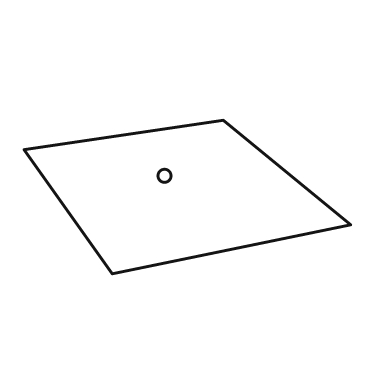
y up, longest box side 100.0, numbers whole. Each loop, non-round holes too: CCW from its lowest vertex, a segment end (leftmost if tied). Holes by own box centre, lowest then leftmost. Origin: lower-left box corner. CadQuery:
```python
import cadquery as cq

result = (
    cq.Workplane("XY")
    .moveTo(27.0, 0.0)
    .lineTo(100.0, 15.0)
    .lineTo(61.0, 47.0)
    .lineTo(0.0, 38.0)
    .close()
    .moveTo(43.0, 30.0)
    .circle(2.0)
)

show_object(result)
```